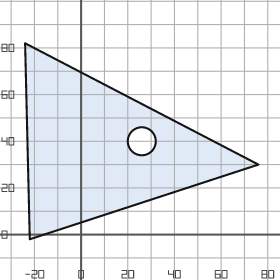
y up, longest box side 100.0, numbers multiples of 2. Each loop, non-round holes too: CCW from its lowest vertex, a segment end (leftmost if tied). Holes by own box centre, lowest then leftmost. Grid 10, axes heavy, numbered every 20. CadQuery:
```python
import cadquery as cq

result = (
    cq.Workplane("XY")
    .moveTo(-22.0, -2.0)
    .lineTo(76.0, 30.0)
    .lineTo(-24.0, 82.0)
    .close()
    .moveTo(26.0, 40.0)
    .circle(6.0)
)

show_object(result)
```